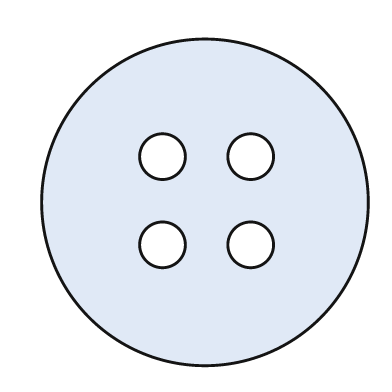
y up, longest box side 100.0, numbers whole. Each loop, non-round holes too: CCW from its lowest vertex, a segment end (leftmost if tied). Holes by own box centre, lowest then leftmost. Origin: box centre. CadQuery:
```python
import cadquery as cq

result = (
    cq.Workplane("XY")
    .moveTo(0.0, 0.0)
    .circle(50.0)
    .moveTo(-13.0, -13.0)
    .circle(7.0)
    .moveTo(14.0, -13.0)
    .circle(7.0)
    .moveTo(-13.0, 14.0)
    .circle(7.0)
    .moveTo(14.0, 14.0)
    .circle(7.0)
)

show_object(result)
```